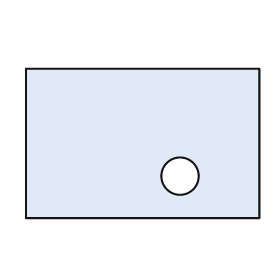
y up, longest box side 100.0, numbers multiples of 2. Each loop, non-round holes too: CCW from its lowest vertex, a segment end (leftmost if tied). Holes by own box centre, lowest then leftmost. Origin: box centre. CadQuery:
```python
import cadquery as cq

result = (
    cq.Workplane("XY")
    .moveTo(-50.0, -32.0)
    .lineTo(50.0, -32.0)
    .lineTo(50.0, 32.0)
    .lineTo(-50.0, 32.0)
    .close()
    .moveTo(16.0, -14.0)
    .circle(8.0)
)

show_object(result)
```